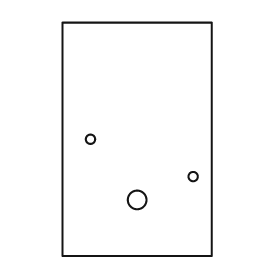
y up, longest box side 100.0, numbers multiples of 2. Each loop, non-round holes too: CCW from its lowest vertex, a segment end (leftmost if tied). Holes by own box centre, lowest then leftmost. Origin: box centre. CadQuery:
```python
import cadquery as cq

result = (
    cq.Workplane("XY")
    .moveTo(-32.0, -50.0)
    .lineTo(32.0, -50.0)
    .lineTo(32.0, 50.0)
    .lineTo(-32.0, 50.0)
    .close()
    .moveTo(0.0, -26.0)
    .circle(4.0)
    .moveTo(24.0, -16.0)
    .circle(2.0)
    .moveTo(-20.0, 0.0)
    .circle(2.0)
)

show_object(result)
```